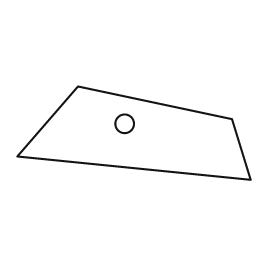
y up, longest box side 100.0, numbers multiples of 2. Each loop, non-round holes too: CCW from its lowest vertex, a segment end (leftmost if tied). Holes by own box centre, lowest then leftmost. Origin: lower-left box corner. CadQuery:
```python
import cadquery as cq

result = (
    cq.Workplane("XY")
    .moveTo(100.0, 0.0)
    .lineTo(92.0, 26.0)
    .lineTo(26.0, 40.0)
    .lineTo(0.0, 10.0)
    .close()
    .moveTo(46.0, 24.0)
    .circle(4.0)
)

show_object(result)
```